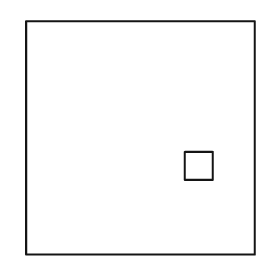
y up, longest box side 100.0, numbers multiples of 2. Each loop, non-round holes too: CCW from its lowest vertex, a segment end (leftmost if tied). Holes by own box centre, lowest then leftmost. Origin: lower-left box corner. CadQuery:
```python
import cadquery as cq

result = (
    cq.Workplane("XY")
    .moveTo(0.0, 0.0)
    .lineTo(98.0, 0.0)
    .lineTo(98.0, 100.0)
    .lineTo(0.0, 100.0)
    .close()
    .moveTo(68.0, 32.0)
    .lineTo(80.0, 32.0)
    .lineTo(80.0, 44.0)
    .lineTo(68.0, 44.0)
    .close()
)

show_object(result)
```